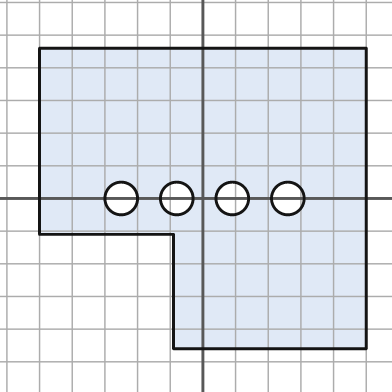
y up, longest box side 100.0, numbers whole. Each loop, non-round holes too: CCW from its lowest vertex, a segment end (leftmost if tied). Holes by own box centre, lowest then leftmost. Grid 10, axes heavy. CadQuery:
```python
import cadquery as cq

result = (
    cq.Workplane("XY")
    .moveTo(-9.0, -46.0)
    .lineTo(50.0, -46.0)
    .lineTo(50.0, 46.0)
    .lineTo(-50.0, 46.0)
    .lineTo(-50.0, -11.0)
    .lineTo(-9.0, -11.0)
    .close()
    .moveTo(-25.0, 0.0)
    .circle(5.0)
    .moveTo(-8.0, 0.0)
    .circle(5.0)
    .moveTo(9.0, 0.0)
    .circle(5.0)
    .moveTo(26.0, 0.0)
    .circle(5.0)
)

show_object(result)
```